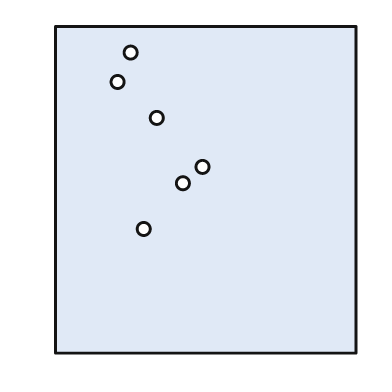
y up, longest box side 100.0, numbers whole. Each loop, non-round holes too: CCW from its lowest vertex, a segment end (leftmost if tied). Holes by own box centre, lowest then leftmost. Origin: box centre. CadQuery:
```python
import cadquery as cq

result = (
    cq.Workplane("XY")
    .moveTo(-46.0, -50.0)
    .lineTo(46.0, -50.0)
    .lineTo(46.0, 50.0)
    .lineTo(-46.0, 50.0)
    .close()
    .moveTo(-19.0, -12.0)
    .circle(2.0)
    .moveTo(-7.0, 2.0)
    .circle(2.0)
    .moveTo(-1.0, 7.0)
    .circle(2.0)
    .moveTo(-15.0, 22.0)
    .circle(2.0)
    .moveTo(-27.0, 33.0)
    .circle(2.0)
    .moveTo(-23.0, 42.0)
    .circle(2.0)
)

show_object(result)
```